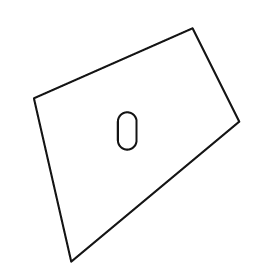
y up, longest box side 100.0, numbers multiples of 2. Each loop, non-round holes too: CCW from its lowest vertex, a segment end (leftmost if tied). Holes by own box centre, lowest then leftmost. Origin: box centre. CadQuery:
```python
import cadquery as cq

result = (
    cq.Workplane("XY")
    .moveTo(-28.0, -50.0)
    .lineTo(44.0, 10.0)
    .lineTo(24.0, 50.0)
    .lineTo(-44.0, 20.0)
    .close()
    .moveTo(-8.0, 2.0)
    .threePointArc((-4.0, -2.0), (0.0, 2.0))
    .lineTo(0.0, 10.0)
    .threePointArc((-4.0, 14.0), (-8.0, 10.0))
    .close()
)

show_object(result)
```